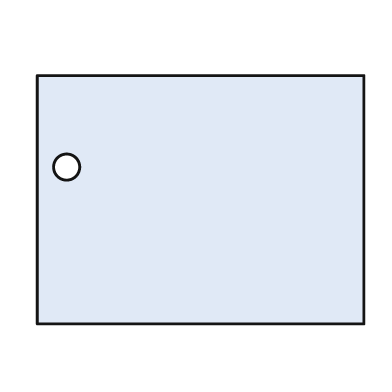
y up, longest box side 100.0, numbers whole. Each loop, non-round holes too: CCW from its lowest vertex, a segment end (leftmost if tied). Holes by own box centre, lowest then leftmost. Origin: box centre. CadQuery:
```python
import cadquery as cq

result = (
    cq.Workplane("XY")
    .moveTo(-50.0, -38.0)
    .lineTo(50.0, -38.0)
    .lineTo(50.0, 38.0)
    .lineTo(-50.0, 38.0)
    .close()
    .moveTo(-41.0, 10.0)
    .circle(4.0)
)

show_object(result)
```